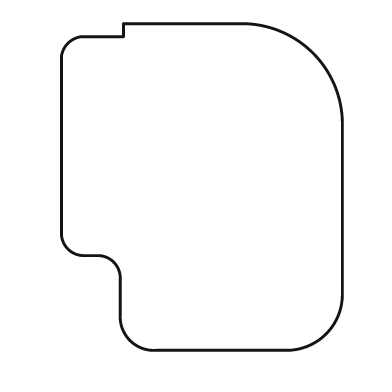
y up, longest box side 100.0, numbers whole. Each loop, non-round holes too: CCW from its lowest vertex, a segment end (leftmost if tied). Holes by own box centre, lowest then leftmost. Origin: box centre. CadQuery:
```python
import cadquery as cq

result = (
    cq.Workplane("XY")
    .moveTo(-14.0, -50.0)
    .lineTo(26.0, -50.0)
    .threePointArc((38.0, -45.0), (43.0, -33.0))
    .lineTo(43.0, 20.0)
    .threePointArc((34.0, 41.0), (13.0, 50.0))
    .lineTo(-24.0, 50.0)
    .lineTo(-24.0, 46.0)
    .lineTo(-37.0, 46.0)
    .threePointArc((-41.0, 44.0), (-43.0, 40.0))
    .lineTo(-43.0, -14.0)
    .threePointArc((-41.0, -19.0), (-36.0, -21.0))
    .lineTo(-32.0, -21.0)
    .threePointArc((-27.0, -23.0), (-25.0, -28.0))
    .lineTo(-25.0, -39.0)
    .threePointArc((-22.0, -47.0), (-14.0, -50.0))
    .close()
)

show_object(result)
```